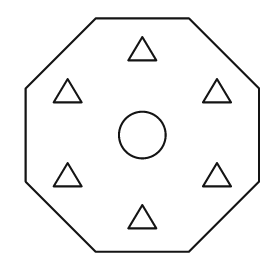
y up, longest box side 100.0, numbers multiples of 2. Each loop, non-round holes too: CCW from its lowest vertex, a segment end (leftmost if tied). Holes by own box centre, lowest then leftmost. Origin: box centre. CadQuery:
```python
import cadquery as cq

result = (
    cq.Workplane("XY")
    .moveTo(-20.0, -50.0)
    .lineTo(20.0, -50.0)
    .lineTo(50.0, -20.0)
    .lineTo(50.0, 20.0)
    .lineTo(20.0, 50.0)
    .lineTo(-20.0, 50.0)
    .lineTo(-50.0, 20.0)
    .lineTo(-50.0, -20.0)
    .close()
    .moveTo(-6.0, -40.0)
    .lineTo(6.0, -40.0)
    .lineTo(0.0, -30.0)
    .close()
    .moveTo(-38.0, -22.0)
    .lineTo(-26.0, -22.0)
    .lineTo(-32.0, -12.0)
    .close()
    .moveTo(26.0, -22.0)
    .lineTo(38.0, -22.0)
    .lineTo(32.0, -12.0)
    .close()
    .moveTo(0.0, 0.0)
    .circle(10.0)
    .moveTo(-38.0, 14.0)
    .lineTo(-26.0, 14.0)
    .lineTo(-32.0, 24.0)
    .close()
    .moveTo(26.0, 14.0)
    .lineTo(38.0, 14.0)
    .lineTo(32.0, 24.0)
    .close()
    .moveTo(-6.0, 32.0)
    .lineTo(6.0, 32.0)
    .lineTo(0.0, 42.0)
    .close()
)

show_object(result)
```